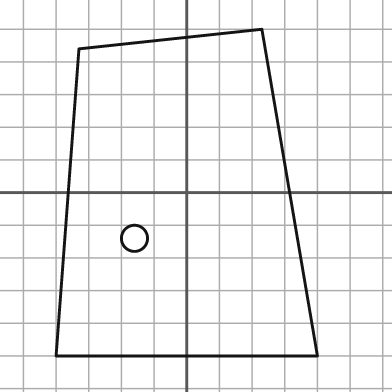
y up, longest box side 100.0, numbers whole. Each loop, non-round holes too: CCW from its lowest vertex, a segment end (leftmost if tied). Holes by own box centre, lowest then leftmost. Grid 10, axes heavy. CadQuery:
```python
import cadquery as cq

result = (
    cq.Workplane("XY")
    .moveTo(-40.0, -50.0)
    .lineTo(40.0, -50.0)
    .lineTo(23.0, 50.0)
    .lineTo(-33.0, 44.0)
    .close()
    .moveTo(-16.0, -14.0)
    .circle(4.0)
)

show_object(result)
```